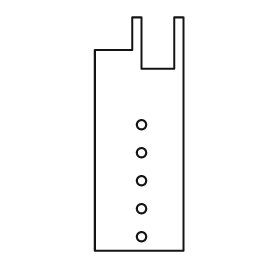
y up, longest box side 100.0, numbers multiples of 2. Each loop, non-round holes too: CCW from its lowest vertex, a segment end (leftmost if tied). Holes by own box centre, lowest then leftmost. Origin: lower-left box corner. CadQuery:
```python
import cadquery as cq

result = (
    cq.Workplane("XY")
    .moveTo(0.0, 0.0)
    .lineTo(38.0, 0.0)
    .lineTo(38.0, 100.0)
    .lineTo(34.0, 100.0)
    .lineTo(34.0, 78.0)
    .lineTo(20.0, 78.0)
    .lineTo(20.0, 100.0)
    .lineTo(16.0, 100.0)
    .lineTo(16.0, 86.0)
    .lineTo(0.0, 86.0)
    .close()
    .moveTo(20.0, 6.0)
    .circle(2.0)
    .moveTo(20.0, 18.0)
    .circle(2.0)
    .moveTo(20.0, 30.0)
    .circle(2.0)
    .moveTo(20.0, 42.0)
    .circle(2.0)
    .moveTo(20.0, 54.0)
    .circle(2.0)
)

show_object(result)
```